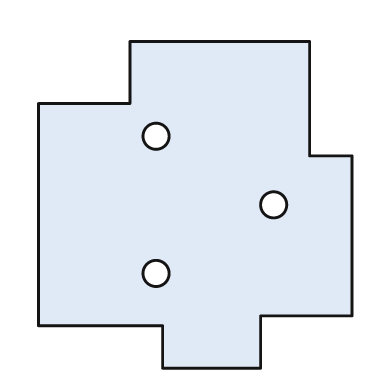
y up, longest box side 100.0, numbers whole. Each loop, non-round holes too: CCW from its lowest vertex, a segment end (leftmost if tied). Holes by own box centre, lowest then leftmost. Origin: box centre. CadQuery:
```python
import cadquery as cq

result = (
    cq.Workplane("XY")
    .moveTo(-10.0, -50.0)
    .lineTo(20.0, -50.0)
    .lineTo(20.0, -34.0)
    .lineTo(48.0, -34.0)
    .lineTo(48.0, 15.0)
    .lineTo(35.0, 15.0)
    .lineTo(35.0, 50.0)
    .lineTo(-20.0, 50.0)
    .lineTo(-20.0, 31.0)
    .lineTo(-48.0, 31.0)
    .lineTo(-48.0, -37.0)
    .lineTo(-10.0, -37.0)
    .close()
    .moveTo(-12.0, -21.0)
    .circle(4.0)
    .moveTo(24.0, 0.0)
    .circle(4.0)
    .moveTo(-12.0, 21.0)
    .circle(4.0)
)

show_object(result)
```